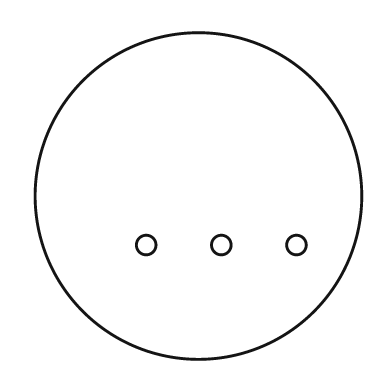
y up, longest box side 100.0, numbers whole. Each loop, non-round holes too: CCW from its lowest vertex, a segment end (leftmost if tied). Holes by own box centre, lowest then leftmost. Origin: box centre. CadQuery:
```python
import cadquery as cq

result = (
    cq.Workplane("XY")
    .moveTo(0.0, 0.0)
    .circle(50.0)
    .moveTo(-16.0, -15.0)
    .circle(3.0)
    .moveTo(7.0, -15.0)
    .circle(3.0)
    .moveTo(30.0, -15.0)
    .circle(3.0)
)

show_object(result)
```